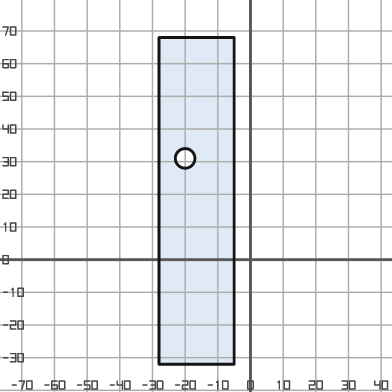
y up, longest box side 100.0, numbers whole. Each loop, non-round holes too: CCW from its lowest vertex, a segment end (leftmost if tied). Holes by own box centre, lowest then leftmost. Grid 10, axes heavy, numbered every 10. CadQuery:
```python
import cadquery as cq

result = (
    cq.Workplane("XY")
    .moveTo(-28.0, -32.0)
    .lineTo(-5.0, -32.0)
    .lineTo(-5.0, 68.0)
    .lineTo(-28.0, 68.0)
    .close()
    .moveTo(-20.0, 31.0)
    .circle(3.0)
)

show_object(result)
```